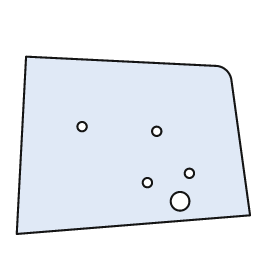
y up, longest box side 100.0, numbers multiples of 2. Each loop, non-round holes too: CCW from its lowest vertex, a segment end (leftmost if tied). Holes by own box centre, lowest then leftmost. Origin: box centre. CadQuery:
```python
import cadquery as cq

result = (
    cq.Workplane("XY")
    .moveTo(-50.0, -38.0)
    .lineTo(50.0, -30.0)
    .lineTo(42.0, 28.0)
    .threePointArc((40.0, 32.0), (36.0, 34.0))
    .lineTo(-46.0, 38.0)
    .close()
    .moveTo(20.0, -24.0)
    .circle(4.0)
    .moveTo(6.0, -16.0)
    .circle(2.0)
    .moveTo(24.0, -12.0)
    .circle(2.0)
    .moveTo(10.0, 6.0)
    .circle(2.0)
    .moveTo(-22.0, 8.0)
    .circle(2.0)
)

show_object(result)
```